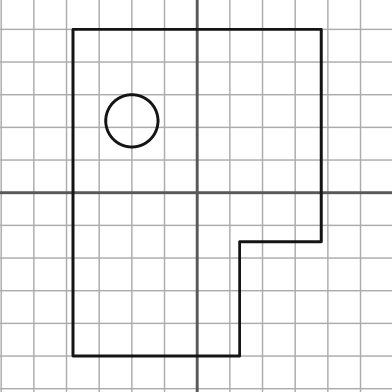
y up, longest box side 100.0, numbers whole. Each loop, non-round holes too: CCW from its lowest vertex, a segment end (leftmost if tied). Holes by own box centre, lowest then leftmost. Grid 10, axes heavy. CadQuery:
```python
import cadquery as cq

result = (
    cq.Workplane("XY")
    .moveTo(-38.0, -50.0)
    .lineTo(13.0, -50.0)
    .lineTo(13.0, -15.0)
    .lineTo(38.0, -15.0)
    .lineTo(38.0, 50.0)
    .lineTo(-38.0, 50.0)
    .close()
    .moveTo(-20.0, 22.0)
    .circle(8.0)
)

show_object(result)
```